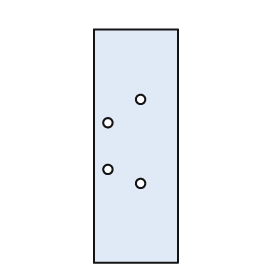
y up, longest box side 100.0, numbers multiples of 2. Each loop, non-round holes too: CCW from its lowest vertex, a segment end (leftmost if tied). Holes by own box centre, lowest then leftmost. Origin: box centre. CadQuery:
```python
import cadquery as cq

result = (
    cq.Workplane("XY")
    .moveTo(-18.0, -50.0)
    .lineTo(18.0, -50.0)
    .lineTo(18.0, 50.0)
    .lineTo(-18.0, 50.0)
    .close()
    .moveTo(2.0, -16.0)
    .circle(2.0)
    .moveTo(-12.0, -10.0)
    .circle(2.0)
    .moveTo(-12.0, 10.0)
    .circle(2.0)
    .moveTo(2.0, 20.0)
    .circle(2.0)
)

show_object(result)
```